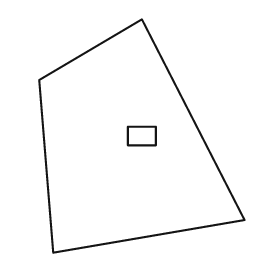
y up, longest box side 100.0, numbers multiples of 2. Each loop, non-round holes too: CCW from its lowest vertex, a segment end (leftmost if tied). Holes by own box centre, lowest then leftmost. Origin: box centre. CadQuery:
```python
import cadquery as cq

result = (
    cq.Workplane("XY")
    .moveTo(-38.0, -50.0)
    .lineTo(44.0, -36.0)
    .lineTo(0.0, 50.0)
    .lineTo(-44.0, 24.0)
    .close()
    .moveTo(-6.0, -4.0)
    .lineTo(6.0, -4.0)
    .lineTo(6.0, 4.0)
    .lineTo(-6.0, 4.0)
    .close()
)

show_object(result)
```